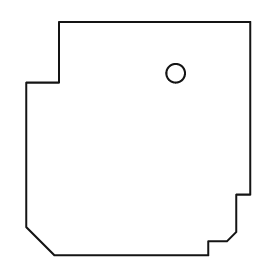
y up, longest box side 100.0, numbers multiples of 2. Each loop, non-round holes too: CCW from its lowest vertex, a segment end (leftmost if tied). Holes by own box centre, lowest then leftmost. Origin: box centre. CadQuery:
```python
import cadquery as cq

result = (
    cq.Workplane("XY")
    .moveTo(-36.0, -50.0)
    .lineTo(30.0, -50.0)
    .lineTo(30.0, -44.0)
    .lineTo(38.0, -44.0)
    .lineTo(42.0, -40.0)
    .lineTo(42.0, -24.0)
    .lineTo(48.0, -24.0)
    .lineTo(48.0, 50.0)
    .lineTo(-34.0, 50.0)
    .lineTo(-34.0, 24.0)
    .lineTo(-48.0, 24.0)
    .lineTo(-48.0, -38.0)
    .close()
    .moveTo(16.0, 28.0)
    .circle(4.0)
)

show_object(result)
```